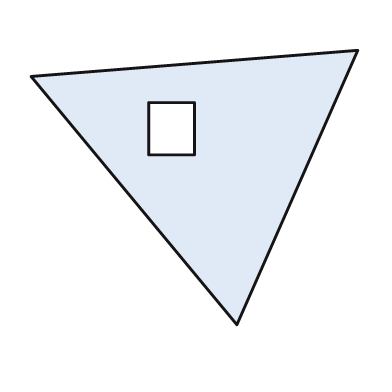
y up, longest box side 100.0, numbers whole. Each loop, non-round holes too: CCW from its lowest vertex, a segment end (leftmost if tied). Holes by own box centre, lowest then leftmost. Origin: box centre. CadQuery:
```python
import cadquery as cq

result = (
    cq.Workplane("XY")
    .moveTo(13.0, -42.0)
    .lineTo(50.0, 42.0)
    .lineTo(-50.0, 34.0)
    .close()
    .moveTo(-14.0, 10.0)
    .lineTo(0.0, 10.0)
    .lineTo(0.0, 26.0)
    .lineTo(-14.0, 26.0)
    .close()
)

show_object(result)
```